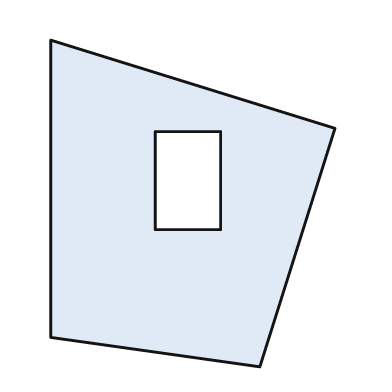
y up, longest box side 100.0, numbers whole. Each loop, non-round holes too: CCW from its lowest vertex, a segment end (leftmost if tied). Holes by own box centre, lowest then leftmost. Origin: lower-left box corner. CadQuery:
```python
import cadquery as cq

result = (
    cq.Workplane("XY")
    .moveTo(64.0, 0.0)
    .lineTo(87.0, 73.0)
    .lineTo(0.0, 100.0)
    .lineTo(0.0, 9.0)
    .close()
    .moveTo(32.0, 42.0)
    .lineTo(52.0, 42.0)
    .lineTo(52.0, 72.0)
    .lineTo(32.0, 72.0)
    .close()
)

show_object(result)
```